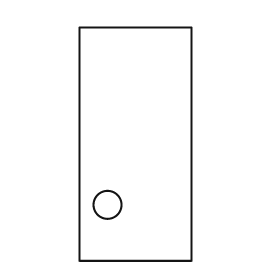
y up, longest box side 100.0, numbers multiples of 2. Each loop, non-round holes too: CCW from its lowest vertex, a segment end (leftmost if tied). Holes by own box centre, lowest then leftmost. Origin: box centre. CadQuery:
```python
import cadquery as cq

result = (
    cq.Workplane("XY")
    .moveTo(-24.0, -50.0)
    .lineTo(24.0, -50.0)
    .lineTo(24.0, 50.0)
    .lineTo(-24.0, 50.0)
    .close()
    .moveTo(-12.0, -26.0)
    .circle(6.0)
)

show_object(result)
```